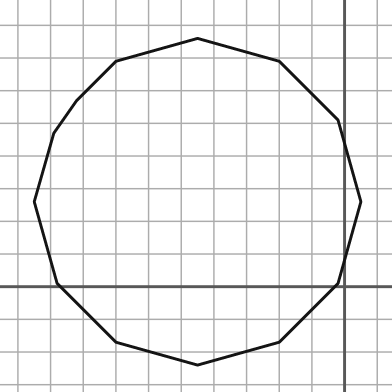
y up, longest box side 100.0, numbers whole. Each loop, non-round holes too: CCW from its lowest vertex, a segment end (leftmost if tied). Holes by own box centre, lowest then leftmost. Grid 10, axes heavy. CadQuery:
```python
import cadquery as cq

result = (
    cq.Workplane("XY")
    .moveTo(-45.0, -24.0)
    .lineTo(-20.0, -17.0)
    .lineTo(-2.0, 1.0)
    .lineTo(5.0, 26.0)
    .lineTo(-2.0, 51.0)
    .lineTo(-20.0, 69.0)
    .lineTo(-45.0, 76.0)
    .lineTo(-70.0, 69.0)
    .lineTo(-82.0, 57.0)
    .lineTo(-89.0, 47.0)
    .lineTo(-95.0, 26.0)
    .lineTo(-88.0, 1.0)
    .lineTo(-70.0, -17.0)
    .close()
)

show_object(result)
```